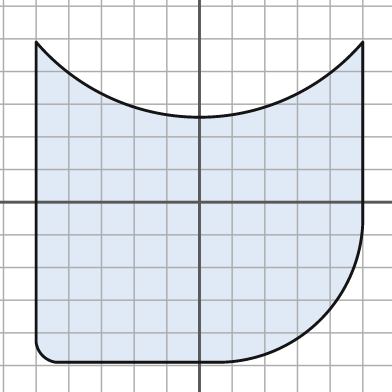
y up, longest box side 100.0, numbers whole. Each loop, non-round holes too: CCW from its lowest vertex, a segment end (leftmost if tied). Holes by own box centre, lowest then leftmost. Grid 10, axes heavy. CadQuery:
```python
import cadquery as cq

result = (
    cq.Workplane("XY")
    .moveTo(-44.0, -49.0)
    .lineTo(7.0, -49.0)
    .threePointArc((37.0, -36.0), (50.0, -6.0))
    .lineTo(50.0, 49.0)
    .threePointArc((0.0, 26.0), (-50.0, 49.0))
    .lineTo(-50.0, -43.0)
    .threePointArc((-48.0, -47.0), (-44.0, -49.0))
    .close()
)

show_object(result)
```